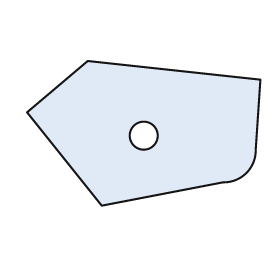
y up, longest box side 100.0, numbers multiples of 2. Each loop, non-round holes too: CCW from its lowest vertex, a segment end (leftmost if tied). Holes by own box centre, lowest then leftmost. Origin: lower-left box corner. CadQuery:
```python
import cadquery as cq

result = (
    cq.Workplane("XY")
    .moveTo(32.0, 0.0)
    .lineTo(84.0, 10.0)
    .threePointArc((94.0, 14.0), (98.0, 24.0))
    .lineTo(100.0, 54.0)
    .lineTo(26.0, 62.0)
    .lineTo(0.0, 40.0)
    .close()
    .moveTo(50.0, 30.0)
    .circle(6.0)
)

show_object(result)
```